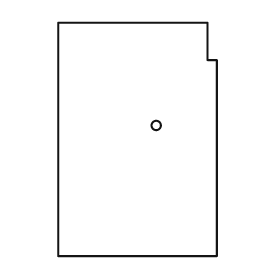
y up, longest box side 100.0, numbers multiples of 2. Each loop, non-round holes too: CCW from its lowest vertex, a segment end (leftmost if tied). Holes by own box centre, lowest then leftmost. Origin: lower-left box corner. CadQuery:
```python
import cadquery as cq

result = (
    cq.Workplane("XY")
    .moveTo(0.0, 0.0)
    .lineTo(68.0, 0.0)
    .lineTo(68.0, 84.0)
    .lineTo(64.0, 84.0)
    .lineTo(64.0, 100.0)
    .lineTo(0.0, 100.0)
    .close()
    .moveTo(42.0, 56.0)
    .circle(2.0)
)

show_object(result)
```